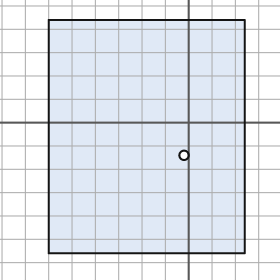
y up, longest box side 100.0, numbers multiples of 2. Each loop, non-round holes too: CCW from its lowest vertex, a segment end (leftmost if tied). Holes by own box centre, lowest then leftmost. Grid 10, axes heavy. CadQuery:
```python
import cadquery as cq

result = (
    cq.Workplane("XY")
    .moveTo(-60.0, -56.0)
    .lineTo(24.0, -56.0)
    .lineTo(24.0, 44.0)
    .lineTo(-60.0, 44.0)
    .close()
    .moveTo(-2.0, -14.0)
    .circle(2.0)
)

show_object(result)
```